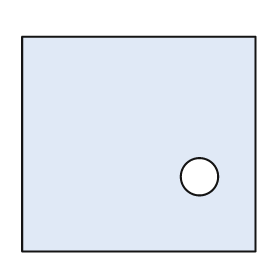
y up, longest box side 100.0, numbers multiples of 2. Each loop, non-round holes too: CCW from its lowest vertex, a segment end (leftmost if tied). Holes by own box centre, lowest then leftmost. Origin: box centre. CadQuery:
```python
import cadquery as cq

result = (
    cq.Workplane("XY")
    .moveTo(-50.0, -46.0)
    .lineTo(50.0, -46.0)
    .lineTo(50.0, 46.0)
    .lineTo(-50.0, 46.0)
    .close()
    .moveTo(26.0, -14.0)
    .circle(8.0)
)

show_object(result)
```